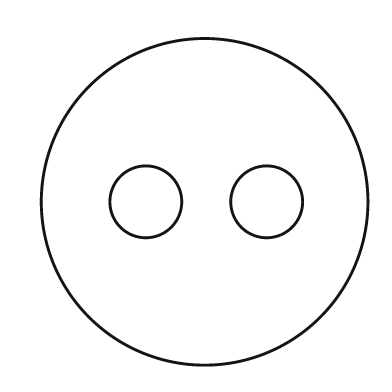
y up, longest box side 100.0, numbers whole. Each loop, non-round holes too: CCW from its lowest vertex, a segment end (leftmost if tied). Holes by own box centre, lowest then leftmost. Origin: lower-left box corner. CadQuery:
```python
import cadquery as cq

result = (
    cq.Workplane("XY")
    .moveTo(50.0, 50.0)
    .circle(50.0)
    .moveTo(32.0, 50.0)
    .circle(11.0)
    .moveTo(69.0, 50.0)
    .circle(11.0)
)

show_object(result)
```